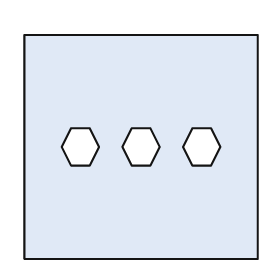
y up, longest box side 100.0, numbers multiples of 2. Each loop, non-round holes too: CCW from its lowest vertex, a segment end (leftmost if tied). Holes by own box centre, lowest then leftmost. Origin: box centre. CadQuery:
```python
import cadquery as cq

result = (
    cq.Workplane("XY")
    .moveTo(-50.0, -48.0)
    .lineTo(50.0, -48.0)
    .lineTo(50.0, 48.0)
    .lineTo(-50.0, 48.0)
    .close()
    .moveTo(-30.0, -8.0)
    .lineTo(-22.0, -8.0)
    .lineTo(-18.0, 0.0)
    .lineTo(-22.0, 8.0)
    .lineTo(-30.0, 8.0)
    .lineTo(-34.0, 0.0)
    .close()
    .moveTo(-4.0, -8.0)
    .lineTo(4.0, -8.0)
    .lineTo(8.0, 0.0)
    .lineTo(4.0, 8.0)
    .lineTo(-4.0, 8.0)
    .lineTo(-8.0, 0.0)
    .close()
    .moveTo(22.0, -8.0)
    .lineTo(30.0, -8.0)
    .lineTo(34.0, 0.0)
    .lineTo(30.0, 8.0)
    .lineTo(22.0, 8.0)
    .lineTo(18.0, 0.0)
    .close()
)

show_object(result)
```